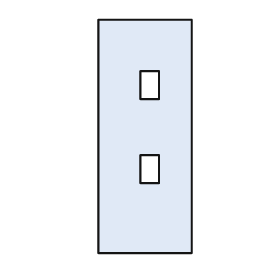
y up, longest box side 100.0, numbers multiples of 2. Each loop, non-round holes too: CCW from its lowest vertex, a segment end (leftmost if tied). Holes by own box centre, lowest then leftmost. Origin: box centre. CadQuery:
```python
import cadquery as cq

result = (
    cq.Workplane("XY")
    .moveTo(-20.0, -50.0)
    .lineTo(20.0, -50.0)
    .lineTo(20.0, 50.0)
    .lineTo(-20.0, 50.0)
    .close()
    .moveTo(-2.0, -20.0)
    .lineTo(6.0, -20.0)
    .lineTo(6.0, -8.0)
    .lineTo(-2.0, -8.0)
    .close()
    .moveTo(-2.0, 16.0)
    .lineTo(6.0, 16.0)
    .lineTo(6.0, 28.0)
    .lineTo(-2.0, 28.0)
    .close()
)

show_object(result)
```